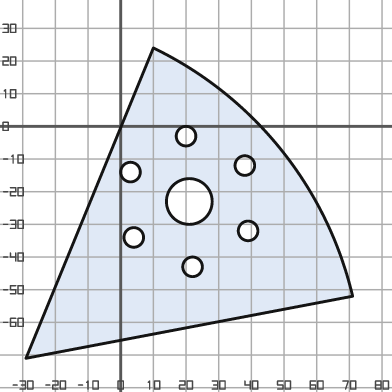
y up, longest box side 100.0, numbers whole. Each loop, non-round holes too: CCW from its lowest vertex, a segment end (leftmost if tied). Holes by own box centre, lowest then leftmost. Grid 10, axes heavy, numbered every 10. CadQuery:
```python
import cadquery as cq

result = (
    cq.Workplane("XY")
    .moveTo(-29.0, -71.0)
    .lineTo(71.0, -52.0)
    .threePointArc((49.0, -7.0), (10.0, 24.0))
    .close()
    .moveTo(22.0, -43.0)
    .circle(3.0)
    .moveTo(4.0, -34.0)
    .circle(3.0)
    .moveTo(39.0, -32.0)
    .circle(3.0)
    .moveTo(21.0, -23.0)
    .circle(7.0)
    .moveTo(3.0, -14.0)
    .circle(3.0)
    .moveTo(38.0, -12.0)
    .circle(3.0)
    .moveTo(20.0, -3.0)
    .circle(3.0)
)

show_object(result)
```